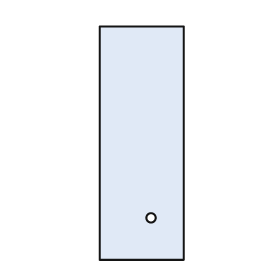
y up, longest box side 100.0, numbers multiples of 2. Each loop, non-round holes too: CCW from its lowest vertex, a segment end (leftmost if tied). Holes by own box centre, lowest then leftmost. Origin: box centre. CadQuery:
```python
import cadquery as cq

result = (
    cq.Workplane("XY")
    .moveTo(-18.0, -50.0)
    .lineTo(18.0, -50.0)
    .lineTo(18.0, 50.0)
    .lineTo(-18.0, 50.0)
    .close()
    .moveTo(4.0, -32.0)
    .circle(2.0)
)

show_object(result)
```